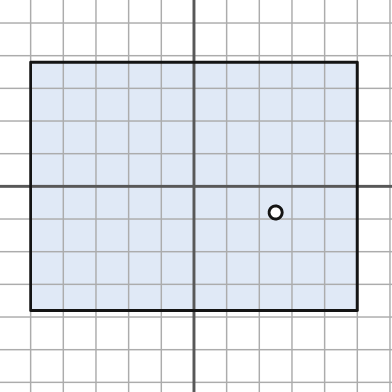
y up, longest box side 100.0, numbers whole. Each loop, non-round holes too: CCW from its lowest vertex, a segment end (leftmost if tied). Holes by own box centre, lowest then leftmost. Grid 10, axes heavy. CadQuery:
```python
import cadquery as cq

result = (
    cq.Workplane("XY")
    .moveTo(-50.0, -38.0)
    .lineTo(50.0, -38.0)
    .lineTo(50.0, 38.0)
    .lineTo(-50.0, 38.0)
    .close()
    .moveTo(25.0, -8.0)
    .circle(2.0)
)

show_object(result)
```